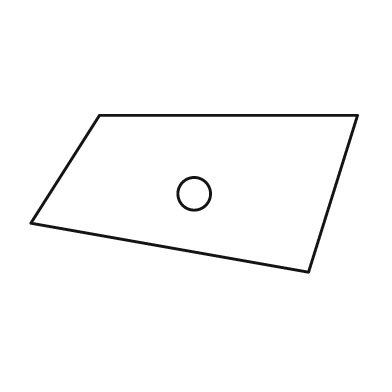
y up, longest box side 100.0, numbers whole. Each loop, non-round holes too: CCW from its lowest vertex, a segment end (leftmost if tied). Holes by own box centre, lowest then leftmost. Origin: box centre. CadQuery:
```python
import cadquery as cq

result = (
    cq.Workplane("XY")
    .moveTo(35.0, -24.0)
    .lineTo(50.0, 24.0)
    .lineTo(-29.0, 24.0)
    .lineTo(-50.0, -9.0)
    .close()
    .moveTo(0.0, 0.0)
    .circle(5.0)
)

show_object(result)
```